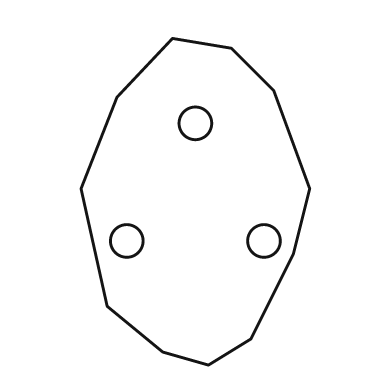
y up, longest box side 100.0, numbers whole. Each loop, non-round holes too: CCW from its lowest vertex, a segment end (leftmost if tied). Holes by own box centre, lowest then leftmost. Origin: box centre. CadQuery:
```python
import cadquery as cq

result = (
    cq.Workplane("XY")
    .moveTo(4.0, -50.0)
    .lineTo(17.0, -42.0)
    .lineTo(30.0, -16.0)
    .lineTo(35.0, 4.0)
    .lineTo(24.0, 34.0)
    .lineTo(11.0, 47.0)
    .lineTo(-7.0, 50.0)
    .lineTo(-24.0, 32.0)
    .lineTo(-35.0, 4.0)
    .lineTo(-27.0, -32.0)
    .lineTo(-10.0, -46.0)
    .close()
    .moveTo(-21.0, -12.0)
    .circle(5.0)
    .moveTo(21.0, -12.0)
    .circle(5.0)
    .moveTo(0.0, 24.0)
    .circle(5.0)
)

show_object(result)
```